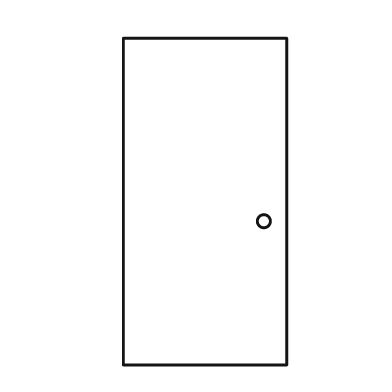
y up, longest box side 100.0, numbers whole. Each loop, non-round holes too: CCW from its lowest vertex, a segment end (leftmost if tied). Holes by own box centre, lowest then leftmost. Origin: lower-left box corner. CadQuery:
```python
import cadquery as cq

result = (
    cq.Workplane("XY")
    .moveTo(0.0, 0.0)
    .lineTo(50.0, 0.0)
    .lineTo(50.0, 100.0)
    .lineTo(0.0, 100.0)
    .close()
    .moveTo(43.0, 44.0)
    .circle(2.0)
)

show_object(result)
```